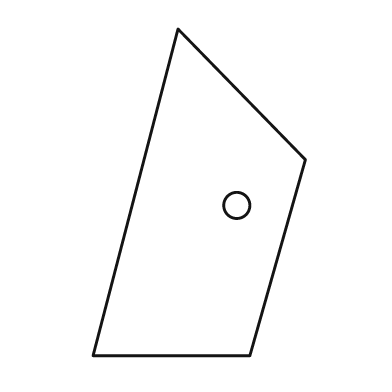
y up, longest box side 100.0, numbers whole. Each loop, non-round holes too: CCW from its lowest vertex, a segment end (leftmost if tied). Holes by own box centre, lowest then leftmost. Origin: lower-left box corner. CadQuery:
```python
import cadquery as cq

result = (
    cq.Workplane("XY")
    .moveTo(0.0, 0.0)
    .lineTo(48.0, 0.0)
    .lineTo(65.0, 60.0)
    .lineTo(26.0, 100.0)
    .close()
    .moveTo(44.0, 46.0)
    .circle(4.0)
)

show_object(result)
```